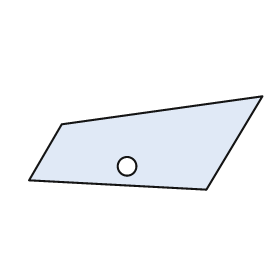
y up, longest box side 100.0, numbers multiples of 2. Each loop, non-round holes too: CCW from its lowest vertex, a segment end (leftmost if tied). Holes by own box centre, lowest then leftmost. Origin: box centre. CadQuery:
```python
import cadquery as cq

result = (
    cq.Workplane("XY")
    .moveTo(26.0, -20.0)
    .lineTo(50.0, 20.0)
    .lineTo(-36.0, 8.0)
    .lineTo(-50.0, -16.0)
    .close()
    .moveTo(-8.0, -10.0)
    .circle(4.0)
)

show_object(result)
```